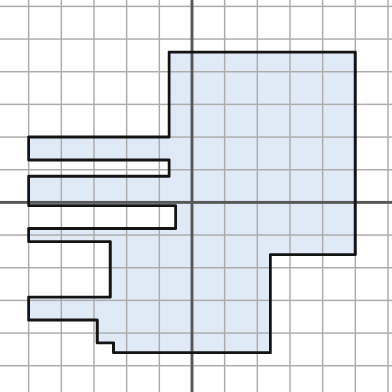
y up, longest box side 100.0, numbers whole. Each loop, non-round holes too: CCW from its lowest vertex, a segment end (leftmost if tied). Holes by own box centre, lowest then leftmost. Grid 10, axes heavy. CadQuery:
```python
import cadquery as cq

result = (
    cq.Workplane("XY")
    .moveTo(-24.0, -46.0)
    .lineTo(24.0, -46.0)
    .lineTo(24.0, -16.0)
    .lineTo(50.0, -16.0)
    .lineTo(50.0, 46.0)
    .lineTo(-7.0, 46.0)
    .lineTo(-7.0, 20.0)
    .lineTo(-50.0, 20.0)
    .lineTo(-50.0, 13.0)
    .lineTo(-7.0, 13.0)
    .lineTo(-7.0, 8.0)
    .lineTo(-50.0, 8.0)
    .lineTo(-50.0, -1.0)
    .lineTo(-5.0, -1.0)
    .lineTo(-5.0, -8.0)
    .lineTo(-50.0, -8.0)
    .lineTo(-50.0, -12.0)
    .lineTo(-25.0, -12.0)
    .lineTo(-25.0, -29.0)
    .lineTo(-50.0, -29.0)
    .lineTo(-50.0, -36.0)
    .lineTo(-29.0, -36.0)
    .lineTo(-29.0, -43.0)
    .lineTo(-24.0, -43.0)
    .close()
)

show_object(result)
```